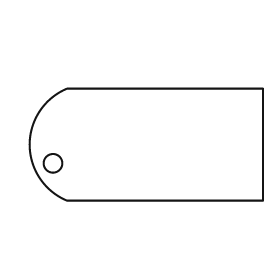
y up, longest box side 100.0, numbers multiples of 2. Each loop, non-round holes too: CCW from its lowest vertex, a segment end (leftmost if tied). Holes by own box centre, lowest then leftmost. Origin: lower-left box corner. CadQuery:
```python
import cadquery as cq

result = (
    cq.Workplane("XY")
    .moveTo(16.0, 0.0)
    .lineTo(100.0, 0.0)
    .lineTo(100.0, 48.0)
    .lineTo(16.0, 48.0)
    .threePointArc((0.0, 24.0), (16.0, 0.0))
    .close()
    .moveTo(10.0, 16.0)
    .circle(4.0)
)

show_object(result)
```